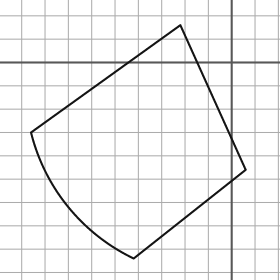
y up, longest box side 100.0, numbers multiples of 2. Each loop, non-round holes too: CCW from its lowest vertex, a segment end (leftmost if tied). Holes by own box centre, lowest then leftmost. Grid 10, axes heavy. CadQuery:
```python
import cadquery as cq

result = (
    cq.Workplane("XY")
    .moveTo(-42.0, -84.0)
    .lineTo(6.0, -46.0)
    .lineTo(-22.0, 16.0)
    .lineTo(-86.0, -30.0)
    .threePointArc((-70.0, -62.0), (-42.0, -84.0))
    .close()
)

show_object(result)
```